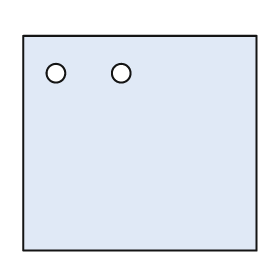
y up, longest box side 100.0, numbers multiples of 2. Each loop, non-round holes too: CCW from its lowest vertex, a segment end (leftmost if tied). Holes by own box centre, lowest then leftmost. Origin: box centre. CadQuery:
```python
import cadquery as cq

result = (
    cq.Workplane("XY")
    .moveTo(-50.0, -46.0)
    .lineTo(50.0, -46.0)
    .lineTo(50.0, 46.0)
    .lineTo(-50.0, 46.0)
    .close()
    .moveTo(-36.0, 30.0)
    .circle(4.0)
    .moveTo(-8.0, 30.0)
    .circle(4.0)
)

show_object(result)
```